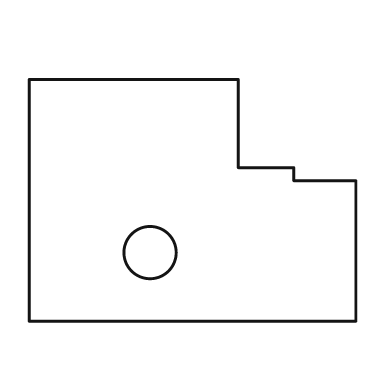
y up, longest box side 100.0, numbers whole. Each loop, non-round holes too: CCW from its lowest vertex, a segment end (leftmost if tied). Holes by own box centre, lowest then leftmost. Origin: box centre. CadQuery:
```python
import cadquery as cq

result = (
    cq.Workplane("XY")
    .moveTo(-50.0, -37.0)
    .lineTo(50.0, -37.0)
    .lineTo(50.0, 6.0)
    .lineTo(31.0, 6.0)
    .lineTo(31.0, 10.0)
    .lineTo(14.0, 10.0)
    .lineTo(14.0, 37.0)
    .lineTo(-50.0, 37.0)
    .close()
    .moveTo(-13.0, -16.0)
    .circle(8.0)
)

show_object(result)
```